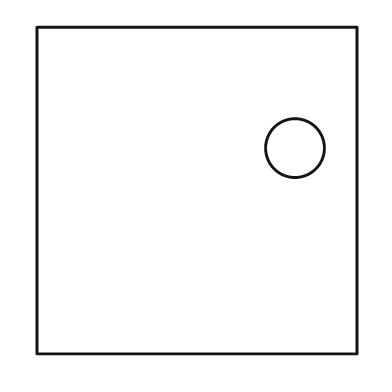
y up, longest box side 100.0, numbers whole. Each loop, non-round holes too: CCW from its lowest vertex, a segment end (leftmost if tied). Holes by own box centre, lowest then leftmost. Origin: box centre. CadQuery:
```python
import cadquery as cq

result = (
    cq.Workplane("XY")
    .moveTo(-49.0, -50.0)
    .lineTo(49.0, -50.0)
    .lineTo(49.0, 50.0)
    .lineTo(-49.0, 50.0)
    .close()
    .moveTo(30.0, 13.0)
    .circle(9.0)
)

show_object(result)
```